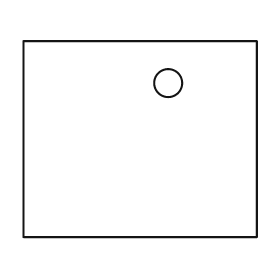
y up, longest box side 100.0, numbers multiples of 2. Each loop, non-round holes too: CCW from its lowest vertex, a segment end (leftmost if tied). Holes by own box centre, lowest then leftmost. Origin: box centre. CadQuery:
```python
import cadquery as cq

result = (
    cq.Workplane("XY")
    .moveTo(-50.0, -42.0)
    .lineTo(50.0, -42.0)
    .lineTo(50.0, 42.0)
    .lineTo(-50.0, 42.0)
    .close()
    .moveTo(12.0, 24.0)
    .circle(6.0)
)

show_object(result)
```